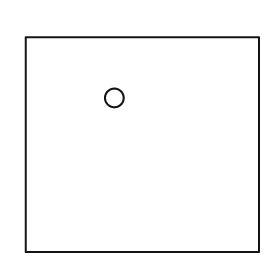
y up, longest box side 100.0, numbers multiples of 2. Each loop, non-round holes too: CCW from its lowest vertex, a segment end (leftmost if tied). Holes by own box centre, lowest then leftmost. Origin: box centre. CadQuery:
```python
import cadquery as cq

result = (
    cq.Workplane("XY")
    .moveTo(-50.0, -46.0)
    .lineTo(50.0, -46.0)
    .lineTo(50.0, 46.0)
    .lineTo(-50.0, 46.0)
    .close()
    .moveTo(-12.0, 20.0)
    .circle(4.0)
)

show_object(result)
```